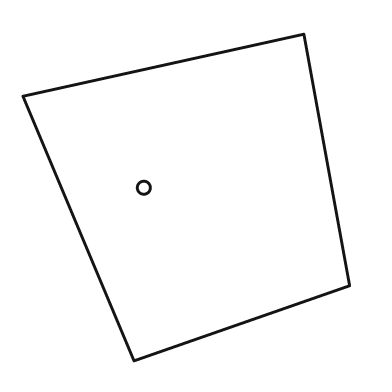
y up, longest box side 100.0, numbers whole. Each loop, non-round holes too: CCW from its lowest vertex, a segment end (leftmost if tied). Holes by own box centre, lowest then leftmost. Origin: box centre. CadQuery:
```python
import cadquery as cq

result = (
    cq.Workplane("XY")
    .moveTo(-16.0, -50.0)
    .lineTo(50.0, -27.0)
    .lineTo(36.0, 50.0)
    .lineTo(-50.0, 31.0)
    .close()
    .moveTo(-13.0, 3.0)
    .circle(2.0)
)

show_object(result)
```